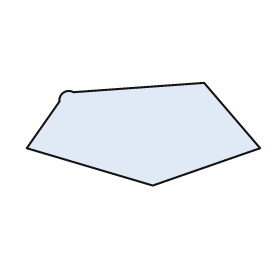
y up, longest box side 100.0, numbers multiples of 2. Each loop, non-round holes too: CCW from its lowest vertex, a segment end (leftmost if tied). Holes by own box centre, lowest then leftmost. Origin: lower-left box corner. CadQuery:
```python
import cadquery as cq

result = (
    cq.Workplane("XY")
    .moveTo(54.0, 0.0)
    .lineTo(100.0, 16.0)
    .lineTo(76.0, 44.0)
    .lineTo(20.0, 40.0)
    .threePointArc((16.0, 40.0), (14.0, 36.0))
    .lineTo(0.0, 16.0)
    .close()
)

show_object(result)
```